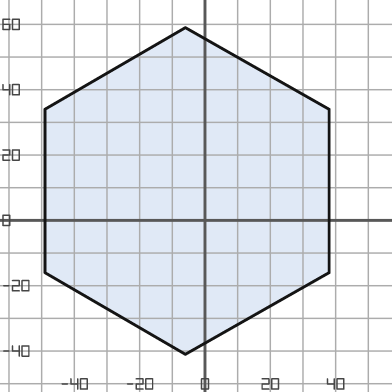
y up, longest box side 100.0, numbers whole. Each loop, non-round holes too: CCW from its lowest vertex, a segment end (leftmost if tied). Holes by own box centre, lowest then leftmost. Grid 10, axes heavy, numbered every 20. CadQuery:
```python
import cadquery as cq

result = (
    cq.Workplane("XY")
    .moveTo(-6.0, -41.0)
    .lineTo(38.0, -16.0)
    .lineTo(38.0, 34.0)
    .lineTo(-6.0, 59.0)
    .lineTo(-49.0, 34.0)
    .lineTo(-49.0, -16.0)
    .close()
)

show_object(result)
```